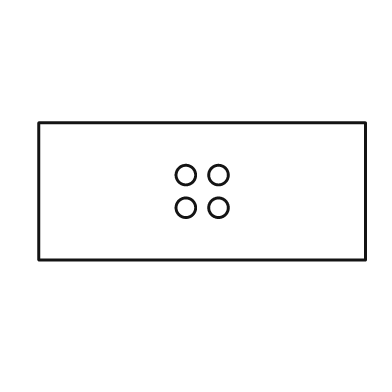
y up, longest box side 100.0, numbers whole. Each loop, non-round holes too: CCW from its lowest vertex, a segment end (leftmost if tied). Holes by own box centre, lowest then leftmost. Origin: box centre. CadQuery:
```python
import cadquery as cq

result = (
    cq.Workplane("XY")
    .moveTo(-50.0, -21.0)
    .lineTo(50.0, -21.0)
    .lineTo(50.0, 21.0)
    .lineTo(-50.0, 21.0)
    .close()
    .moveTo(-5.0, -5.0)
    .circle(3.0)
    .moveTo(5.0, -5.0)
    .circle(3.0)
    .moveTo(-5.0, 5.0)
    .circle(3.0)
    .moveTo(5.0, 5.0)
    .circle(3.0)
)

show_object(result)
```